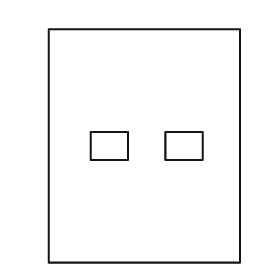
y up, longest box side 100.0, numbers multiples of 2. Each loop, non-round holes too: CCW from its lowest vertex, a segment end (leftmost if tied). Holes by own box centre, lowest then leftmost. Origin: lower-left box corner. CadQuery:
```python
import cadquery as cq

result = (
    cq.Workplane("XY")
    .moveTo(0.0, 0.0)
    .lineTo(82.0, 0.0)
    .lineTo(82.0, 100.0)
    .lineTo(0.0, 100.0)
    .close()
    .moveTo(18.0, 44.0)
    .lineTo(34.0, 44.0)
    .lineTo(34.0, 56.0)
    .lineTo(18.0, 56.0)
    .close()
    .moveTo(50.0, 44.0)
    .lineTo(66.0, 44.0)
    .lineTo(66.0, 56.0)
    .lineTo(50.0, 56.0)
    .close()
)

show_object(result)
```